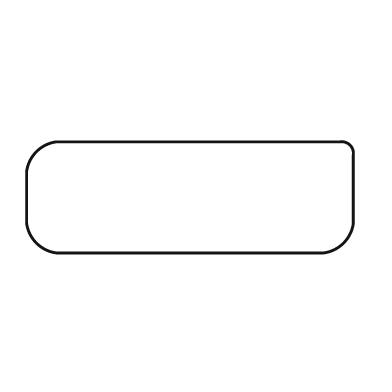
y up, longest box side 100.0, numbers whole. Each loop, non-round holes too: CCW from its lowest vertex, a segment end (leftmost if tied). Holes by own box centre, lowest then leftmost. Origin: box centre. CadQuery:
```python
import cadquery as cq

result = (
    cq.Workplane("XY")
    .moveTo(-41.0, -17.0)
    .lineTo(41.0, -17.0)
    .threePointArc((47.0, -14.0), (50.0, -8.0))
    .lineTo(50.0, 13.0)
    .threePointArc((49.0, 16.0), (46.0, 17.0))
    .lineTo(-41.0, 17.0)
    .threePointArc((-47.0, 14.0), (-50.0, 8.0))
    .lineTo(-50.0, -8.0)
    .threePointArc((-47.0, -14.0), (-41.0, -17.0))
    .close()
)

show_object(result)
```